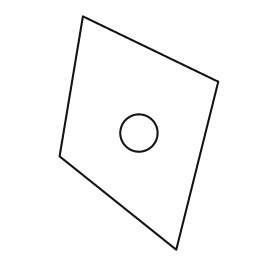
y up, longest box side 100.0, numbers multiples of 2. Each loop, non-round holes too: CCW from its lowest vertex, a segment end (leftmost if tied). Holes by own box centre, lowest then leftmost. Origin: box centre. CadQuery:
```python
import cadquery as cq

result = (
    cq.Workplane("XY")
    .moveTo(16.0, -50.0)
    .lineTo(34.0, 22.0)
    .lineTo(-24.0, 50.0)
    .lineTo(-34.0, -10.0)
    .close()
    .moveTo(0.0, 0.0)
    .circle(8.0)
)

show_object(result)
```